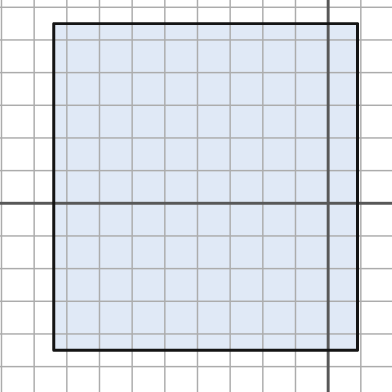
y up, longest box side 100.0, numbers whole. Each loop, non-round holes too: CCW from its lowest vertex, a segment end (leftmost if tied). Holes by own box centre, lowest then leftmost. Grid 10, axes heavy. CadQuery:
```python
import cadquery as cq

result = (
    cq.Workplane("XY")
    .moveTo(-84.0, -45.0)
    .lineTo(9.0, -45.0)
    .lineTo(9.0, 55.0)
    .lineTo(-84.0, 55.0)
    .close()
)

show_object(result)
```